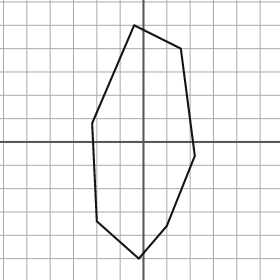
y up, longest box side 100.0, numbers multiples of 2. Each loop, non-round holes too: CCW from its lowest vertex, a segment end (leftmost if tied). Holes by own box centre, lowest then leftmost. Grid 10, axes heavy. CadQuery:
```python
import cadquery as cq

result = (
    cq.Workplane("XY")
    .moveTo(-2.0, -50.0)
    .lineTo(10.0, -36.0)
    .lineTo(22.0, -6.0)
    .lineTo(16.0, 40.0)
    .lineTo(-4.0, 50.0)
    .lineTo(-22.0, 8.0)
    .lineTo(-20.0, -34.0)
    .close()
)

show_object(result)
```